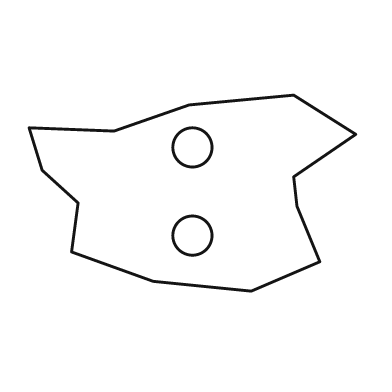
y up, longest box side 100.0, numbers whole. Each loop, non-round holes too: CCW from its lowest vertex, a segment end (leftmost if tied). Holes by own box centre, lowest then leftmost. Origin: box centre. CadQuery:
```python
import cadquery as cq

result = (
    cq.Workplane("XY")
    .moveTo(18.0, -30.0)
    .lineTo(39.0, -21.0)
    .lineTo(32.0, -4.0)
    .lineTo(31.0, 5.0)
    .lineTo(50.0, 18.0)
    .lineTo(31.0, 30.0)
    .lineTo(-1.0, 27.0)
    .lineTo(-24.0, 19.0)
    .lineTo(-50.0, 20.0)
    .lineTo(-46.0, 7.0)
    .lineTo(-35.0, -3.0)
    .lineTo(-37.0, -18.0)
    .lineTo(-12.0, -27.0)
    .close()
    .moveTo(0.0, -13.0)
    .circle(6.0)
    .moveTo(0.0, 14.0)
    .circle(6.0)
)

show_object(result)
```